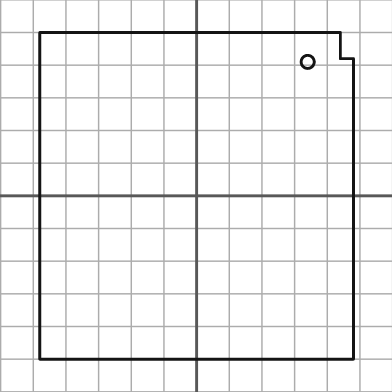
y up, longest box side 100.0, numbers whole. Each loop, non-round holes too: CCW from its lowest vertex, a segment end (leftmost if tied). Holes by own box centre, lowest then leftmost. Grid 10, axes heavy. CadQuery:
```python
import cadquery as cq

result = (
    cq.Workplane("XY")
    .moveTo(-48.0, -50.0)
    .lineTo(48.0, -50.0)
    .lineTo(48.0, 42.0)
    .lineTo(44.0, 42.0)
    .lineTo(44.0, 50.0)
    .lineTo(-48.0, 50.0)
    .close()
    .moveTo(34.0, 41.0)
    .circle(2.0)
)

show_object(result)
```